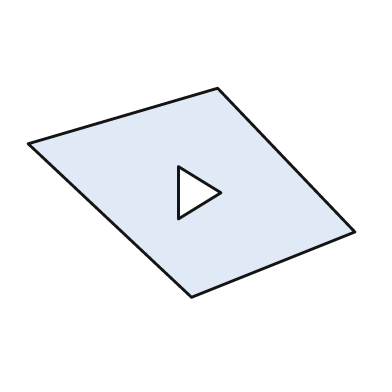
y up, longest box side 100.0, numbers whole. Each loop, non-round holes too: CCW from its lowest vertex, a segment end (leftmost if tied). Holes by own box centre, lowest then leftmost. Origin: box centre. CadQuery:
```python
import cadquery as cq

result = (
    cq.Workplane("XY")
    .moveTo(0.0, -32.0)
    .lineTo(50.0, -12.0)
    .lineTo(8.0, 32.0)
    .lineTo(-50.0, 15.0)
    .close()
    .moveTo(-4.0, -8.0)
    .lineTo(9.0, 0.0)
    .lineTo(-4.0, 8.0)
    .close()
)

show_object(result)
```